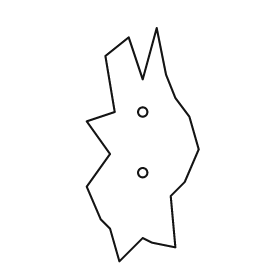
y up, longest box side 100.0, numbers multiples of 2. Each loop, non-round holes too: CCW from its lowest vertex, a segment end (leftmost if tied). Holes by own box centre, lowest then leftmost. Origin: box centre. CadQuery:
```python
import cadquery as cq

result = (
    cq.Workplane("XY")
    .moveTo(-10.0, -50.0)
    .lineTo(0.0, -40.0)
    .lineTo(4.0, -42.0)
    .lineTo(14.0, -44.0)
    .lineTo(12.0, -22.0)
    .lineTo(18.0, -16.0)
    .lineTo(24.0, -2.0)
    .lineTo(20.0, 12.0)
    .lineTo(14.0, 20.0)
    .lineTo(10.0, 30.0)
    .lineTo(6.0, 50.0)
    .lineTo(0.0, 28.0)
    .lineTo(-6.0, 46.0)
    .lineTo(-16.0, 38.0)
    .lineTo(-12.0, 14.0)
    .lineTo(-24.0, 10.0)
    .lineTo(-14.0, -4.0)
    .lineTo(-24.0, -18.0)
    .lineTo(-18.0, -32.0)
    .lineTo(-14.0, -36.0)
    .close()
    .moveTo(0.0, -12.0)
    .circle(2.0)
    .moveTo(0.0, 14.0)
    .circle(2.0)
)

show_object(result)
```